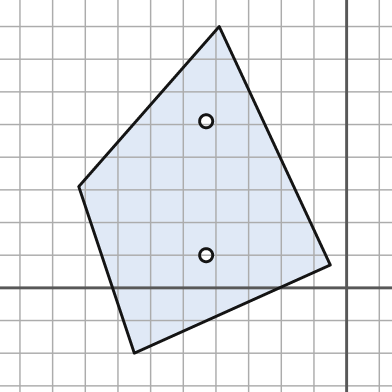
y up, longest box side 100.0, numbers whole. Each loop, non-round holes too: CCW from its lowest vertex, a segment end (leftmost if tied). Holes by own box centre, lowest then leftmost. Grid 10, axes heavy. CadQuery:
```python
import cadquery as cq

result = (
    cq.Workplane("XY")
    .moveTo(-65.0, -20.0)
    .lineTo(-5.0, 7.0)
    .lineTo(-39.0, 80.0)
    .lineTo(-82.0, 31.0)
    .close()
    .moveTo(-43.0, 10.0)
    .circle(2.0)
    .moveTo(-43.0, 51.0)
    .circle(2.0)
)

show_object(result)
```